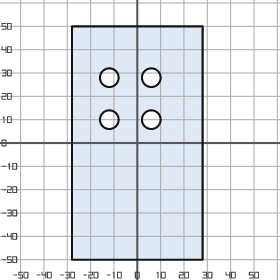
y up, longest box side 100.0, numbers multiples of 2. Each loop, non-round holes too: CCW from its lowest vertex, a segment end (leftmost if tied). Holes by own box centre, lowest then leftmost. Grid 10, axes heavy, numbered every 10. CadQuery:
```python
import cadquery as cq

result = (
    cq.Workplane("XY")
    .moveTo(-28.0, -50.0)
    .lineTo(28.0, -50.0)
    .lineTo(28.0, 50.0)
    .lineTo(-28.0, 50.0)
    .close()
    .moveTo(-12.0, 10.0)
    .circle(4.0)
    .moveTo(6.0, 10.0)
    .circle(4.0)
    .moveTo(-12.0, 28.0)
    .circle(4.0)
    .moveTo(6.0, 28.0)
    .circle(4.0)
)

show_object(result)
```